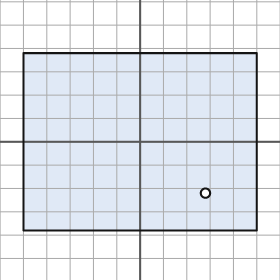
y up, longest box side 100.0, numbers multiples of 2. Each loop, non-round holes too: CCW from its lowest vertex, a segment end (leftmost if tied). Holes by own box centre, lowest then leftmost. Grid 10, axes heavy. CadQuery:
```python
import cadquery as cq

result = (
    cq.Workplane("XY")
    .moveTo(-50.0, -38.0)
    .lineTo(50.0, -38.0)
    .lineTo(50.0, 38.0)
    .lineTo(-50.0, 38.0)
    .close()
    .moveTo(28.0, -22.0)
    .circle(2.0)
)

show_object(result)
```